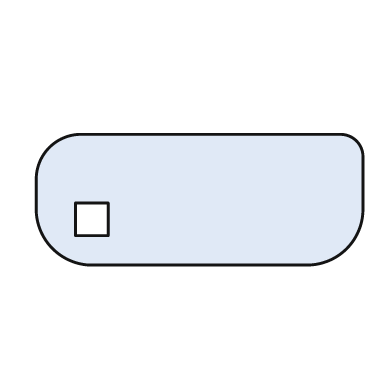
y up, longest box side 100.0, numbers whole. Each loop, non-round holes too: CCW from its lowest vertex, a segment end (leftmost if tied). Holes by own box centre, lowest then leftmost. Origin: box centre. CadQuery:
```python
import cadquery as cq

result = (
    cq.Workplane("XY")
    .moveTo(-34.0, -20.0)
    .lineTo(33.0, -20.0)
    .threePointArc((45.0, -15.0), (50.0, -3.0))
    .lineTo(50.0, 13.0)
    .threePointArc((48.0, 18.0), (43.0, 20.0))
    .lineTo(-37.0, 20.0)
    .threePointArc((-46.0, 16.0), (-50.0, 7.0))
    .lineTo(-50.0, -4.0)
    .threePointArc((-45.0, -15.0), (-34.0, -20.0))
    .close()
    .moveTo(-38.0, -11.0)
    .lineTo(-28.0, -11.0)
    .lineTo(-28.0, -1.0)
    .lineTo(-38.0, -1.0)
    .close()
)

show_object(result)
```